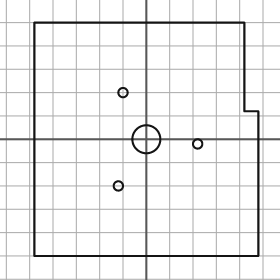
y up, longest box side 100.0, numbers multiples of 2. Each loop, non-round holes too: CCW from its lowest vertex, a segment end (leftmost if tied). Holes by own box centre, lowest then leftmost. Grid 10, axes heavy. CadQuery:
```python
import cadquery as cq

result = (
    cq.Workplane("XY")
    .moveTo(-48.0, -50.0)
    .lineTo(48.0, -50.0)
    .lineTo(48.0, 12.0)
    .lineTo(42.0, 12.0)
    .lineTo(42.0, 50.0)
    .lineTo(-48.0, 50.0)
    .close()
    .moveTo(-12.0, -20.0)
    .circle(2.0)
    .moveTo(22.0, -2.0)
    .circle(2.0)
    .moveTo(0.0, 0.0)
    .circle(6.0)
    .moveTo(-10.0, 20.0)
    .circle(2.0)
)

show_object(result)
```